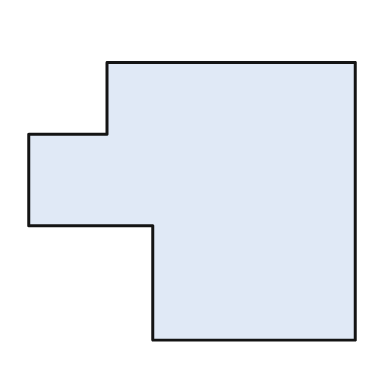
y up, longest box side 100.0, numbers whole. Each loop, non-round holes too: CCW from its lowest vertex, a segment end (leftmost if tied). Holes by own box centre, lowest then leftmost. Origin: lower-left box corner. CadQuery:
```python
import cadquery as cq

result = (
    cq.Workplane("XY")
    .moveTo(38.0, 0.0)
    .lineTo(100.0, 0.0)
    .lineTo(100.0, 85.0)
    .lineTo(24.0, 85.0)
    .lineTo(24.0, 63.0)
    .lineTo(0.0, 63.0)
    .lineTo(0.0, 35.0)
    .lineTo(38.0, 35.0)
    .close()
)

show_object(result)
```